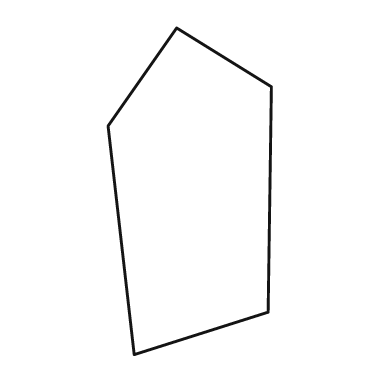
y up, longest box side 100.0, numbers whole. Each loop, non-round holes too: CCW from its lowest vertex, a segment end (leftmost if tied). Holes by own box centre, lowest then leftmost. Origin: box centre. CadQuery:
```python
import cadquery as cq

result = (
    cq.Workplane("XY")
    .moveTo(-17.0, -50.0)
    .lineTo(24.0, -37.0)
    .lineTo(25.0, 32.0)
    .lineTo(-4.0, 50.0)
    .lineTo(-25.0, 20.0)
    .close()
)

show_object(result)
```